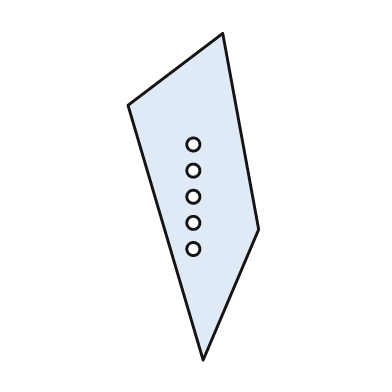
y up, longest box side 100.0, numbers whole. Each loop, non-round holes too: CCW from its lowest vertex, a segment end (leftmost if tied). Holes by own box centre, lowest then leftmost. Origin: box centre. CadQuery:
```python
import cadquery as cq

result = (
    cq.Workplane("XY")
    .moveTo(3.0, -50.0)
    .lineTo(20.0, -10.0)
    .lineTo(9.0, 50.0)
    .lineTo(-20.0, 28.0)
    .close()
    .moveTo(0.0, -16.0)
    .circle(2.0)
    .moveTo(0.0, -8.0)
    .circle(2.0)
    .moveTo(0.0, 0.0)
    .circle(2.0)
    .moveTo(0.0, 8.0)
    .circle(2.0)
    .moveTo(0.0, 16.0)
    .circle(2.0)
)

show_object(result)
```